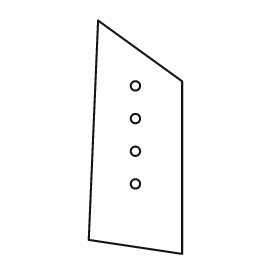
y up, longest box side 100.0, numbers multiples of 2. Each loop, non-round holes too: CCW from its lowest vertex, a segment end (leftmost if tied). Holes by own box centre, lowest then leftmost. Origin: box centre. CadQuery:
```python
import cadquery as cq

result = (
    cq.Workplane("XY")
    .moveTo(20.0, -50.0)
    .lineTo(20.0, 24.0)
    .lineTo(-16.0, 50.0)
    .lineTo(-20.0, -44.0)
    .close()
    .moveTo(0.0, -20.0)
    .circle(2.0)
    .moveTo(0.0, -6.0)
    .circle(2.0)
    .moveTo(0.0, 8.0)
    .circle(2.0)
    .moveTo(0.0, 22.0)
    .circle(2.0)
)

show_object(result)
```